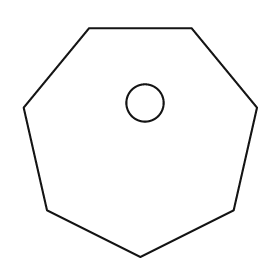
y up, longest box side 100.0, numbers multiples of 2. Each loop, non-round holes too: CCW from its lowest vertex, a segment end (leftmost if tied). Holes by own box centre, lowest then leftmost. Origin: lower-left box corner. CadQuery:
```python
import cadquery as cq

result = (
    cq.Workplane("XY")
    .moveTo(50.0, 0.0)
    .lineTo(90.0, 20.0)
    .lineTo(100.0, 64.0)
    .lineTo(72.0, 98.0)
    .lineTo(28.0, 98.0)
    .lineTo(0.0, 64.0)
    .lineTo(10.0, 20.0)
    .close()
    .moveTo(52.0, 66.0)
    .circle(8.0)
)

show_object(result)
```